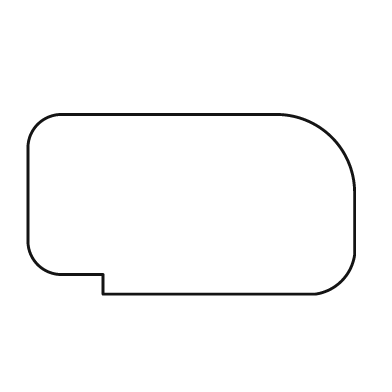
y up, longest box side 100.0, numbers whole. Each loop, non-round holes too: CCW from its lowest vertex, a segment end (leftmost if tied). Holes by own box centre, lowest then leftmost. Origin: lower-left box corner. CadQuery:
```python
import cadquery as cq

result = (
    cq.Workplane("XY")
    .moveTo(23.0, 0.0)
    .lineTo(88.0, 0.0)
    .threePointArc((96.0, 4.0), (100.0, 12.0))
    .lineTo(100.0, 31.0)
    .threePointArc((93.0, 48.0), (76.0, 55.0))
    .lineTo(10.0, 55.0)
    .threePointArc((3.0, 52.0), (0.0, 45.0))
    .lineTo(0.0, 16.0)
    .threePointArc((3.0, 9.0), (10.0, 6.0))
    .lineTo(23.0, 6.0)
    .close()
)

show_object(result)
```